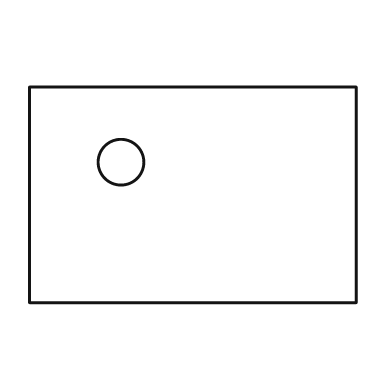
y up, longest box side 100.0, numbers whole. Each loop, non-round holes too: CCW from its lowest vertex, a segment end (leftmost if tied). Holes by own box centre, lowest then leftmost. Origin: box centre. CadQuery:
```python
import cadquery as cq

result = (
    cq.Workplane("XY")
    .moveTo(-50.0, -33.0)
    .lineTo(50.0, -33.0)
    .lineTo(50.0, 33.0)
    .lineTo(-50.0, 33.0)
    .close()
    .moveTo(-22.0, 10.0)
    .circle(7.0)
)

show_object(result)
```